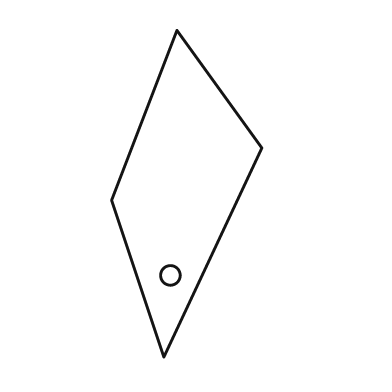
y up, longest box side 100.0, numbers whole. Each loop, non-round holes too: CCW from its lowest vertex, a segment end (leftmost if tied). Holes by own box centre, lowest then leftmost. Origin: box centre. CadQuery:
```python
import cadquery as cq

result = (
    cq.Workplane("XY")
    .moveTo(-7.0, -50.0)
    .lineTo(23.0, 14.0)
    .lineTo(-3.0, 50.0)
    .lineTo(-23.0, -2.0)
    .close()
    .moveTo(-5.0, -25.0)
    .circle(3.0)
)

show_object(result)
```